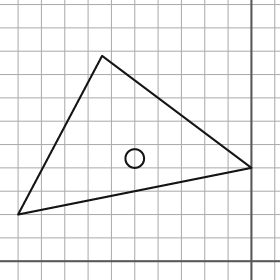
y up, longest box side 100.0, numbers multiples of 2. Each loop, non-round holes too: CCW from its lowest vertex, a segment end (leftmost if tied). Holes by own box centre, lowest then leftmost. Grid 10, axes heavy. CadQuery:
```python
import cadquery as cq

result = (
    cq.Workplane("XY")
    .moveTo(-100.0, 20.0)
    .lineTo(0.0, 40.0)
    .lineTo(-64.0, 88.0)
    .close()
    .moveTo(-50.0, 44.0)
    .circle(4.0)
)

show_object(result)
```